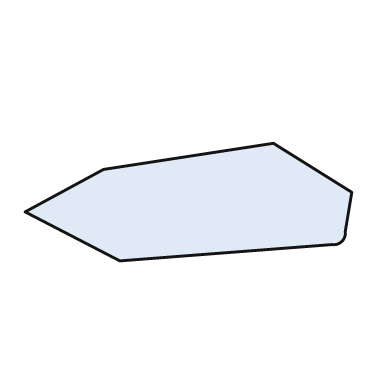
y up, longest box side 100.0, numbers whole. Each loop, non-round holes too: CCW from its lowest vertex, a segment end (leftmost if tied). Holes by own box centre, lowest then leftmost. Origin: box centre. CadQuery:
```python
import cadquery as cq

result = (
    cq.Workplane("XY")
    .moveTo(-21.0, -18.0)
    .lineTo(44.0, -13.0)
    .threePointArc((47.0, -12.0), (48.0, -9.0))
    .lineTo(50.0, 3.0)
    .lineTo(26.0, 18.0)
    .lineTo(-26.0, 10.0)
    .lineTo(-50.0, -3.0)
    .close()
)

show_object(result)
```